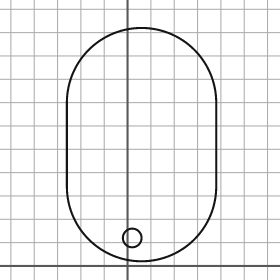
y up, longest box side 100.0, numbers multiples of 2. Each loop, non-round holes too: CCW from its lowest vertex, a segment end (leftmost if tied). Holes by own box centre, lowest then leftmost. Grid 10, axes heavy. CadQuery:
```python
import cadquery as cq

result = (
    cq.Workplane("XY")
    .moveTo(-26.0, 34.0)
    .threePointArc((6.0, 2.0), (38.0, 34.0))
    .lineTo(38.0, 70.0)
    .threePointArc((6.0, 102.0), (-26.0, 70.0))
    .close()
    .moveTo(2.0, 12.0)
    .circle(4.0)
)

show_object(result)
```